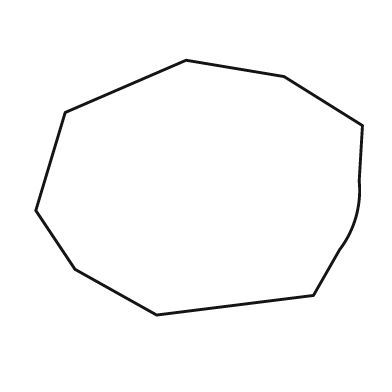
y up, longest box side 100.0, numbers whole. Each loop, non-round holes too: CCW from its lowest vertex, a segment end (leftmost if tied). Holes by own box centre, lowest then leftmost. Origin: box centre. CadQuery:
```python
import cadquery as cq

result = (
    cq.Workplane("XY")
    .moveTo(-13.0, -39.0)
    .lineTo(35.0, -33.0)
    .lineTo(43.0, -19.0)
    .threePointArc((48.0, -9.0), (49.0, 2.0))
    .lineTo(50.0, 19.0)
    .lineTo(26.0, 34.0)
    .lineTo(-4.0, 39.0)
    .lineTo(-41.0, 23.0)
    .lineTo(-50.0, -7.0)
    .lineTo(-38.0, -25.0)
    .close()
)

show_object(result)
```